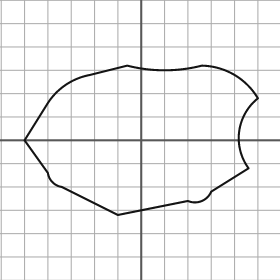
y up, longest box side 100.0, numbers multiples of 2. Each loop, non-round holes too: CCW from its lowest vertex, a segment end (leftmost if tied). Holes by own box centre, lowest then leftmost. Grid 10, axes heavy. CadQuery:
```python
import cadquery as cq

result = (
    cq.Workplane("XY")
    .moveTo(-10.0, -32.0)
    .lineTo(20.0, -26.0)
    .threePointArc((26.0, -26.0), (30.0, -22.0))
    .lineTo(46.0, -12.0)
    .threePointArc((42.0, 4.0), (50.0, 18.0))
    .threePointArc((40.0, 28.0), (26.0, 32.0))
    .threePointArc((10.0, 30.0), (-6.0, 32.0))
    .lineTo(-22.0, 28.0)
    .threePointArc((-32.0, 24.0), (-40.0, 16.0))
    .lineTo(-50.0, 0.0)
    .lineTo(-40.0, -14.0)
    .threePointArc((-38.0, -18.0), (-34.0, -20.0))
    .close()
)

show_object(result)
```